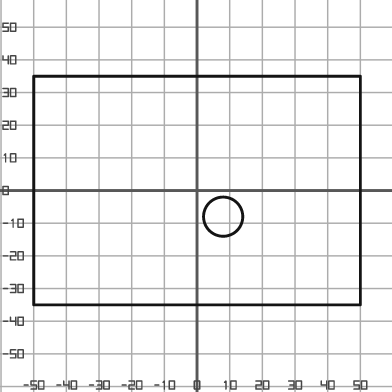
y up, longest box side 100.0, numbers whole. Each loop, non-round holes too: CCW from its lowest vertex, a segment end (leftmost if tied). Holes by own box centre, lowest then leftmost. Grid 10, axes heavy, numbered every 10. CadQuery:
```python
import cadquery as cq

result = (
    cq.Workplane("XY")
    .moveTo(-50.0, -35.0)
    .lineTo(50.0, -35.0)
    .lineTo(50.0, 35.0)
    .lineTo(-50.0, 35.0)
    .close()
    .moveTo(8.0, -8.0)
    .circle(6.0)
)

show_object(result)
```